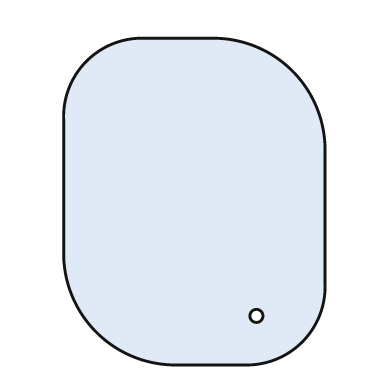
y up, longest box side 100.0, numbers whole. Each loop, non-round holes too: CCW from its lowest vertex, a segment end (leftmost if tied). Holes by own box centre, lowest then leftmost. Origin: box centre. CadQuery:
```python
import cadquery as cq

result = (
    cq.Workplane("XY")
    .moveTo(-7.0, -50.0)
    .lineTo(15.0, -50.0)
    .threePointArc((33.0, -43.0), (40.0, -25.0))
    .lineTo(40.0, 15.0)
    .threePointArc((30.0, 40.0), (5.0, 50.0))
    .lineTo(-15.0, 50.0)
    .threePointArc((-33.0, 43.0), (-40.0, 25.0))
    .lineTo(-40.0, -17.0)
    .threePointArc((-30.0, -40.0), (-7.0, -50.0))
    .close()
    .moveTo(19.0, -35.0)
    .circle(2.0)
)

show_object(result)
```